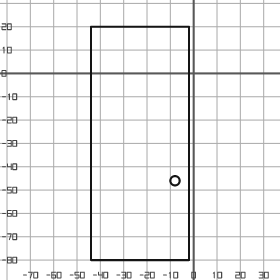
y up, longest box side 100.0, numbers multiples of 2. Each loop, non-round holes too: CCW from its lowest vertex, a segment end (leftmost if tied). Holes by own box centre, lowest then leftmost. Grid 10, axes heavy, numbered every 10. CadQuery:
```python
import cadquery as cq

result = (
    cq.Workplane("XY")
    .moveTo(-44.0, -80.0)
    .lineTo(-2.0, -80.0)
    .lineTo(-2.0, 20.0)
    .lineTo(-44.0, 20.0)
    .close()
    .moveTo(-8.0, -46.0)
    .circle(2.0)
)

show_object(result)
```